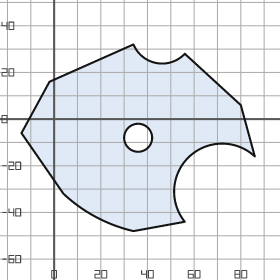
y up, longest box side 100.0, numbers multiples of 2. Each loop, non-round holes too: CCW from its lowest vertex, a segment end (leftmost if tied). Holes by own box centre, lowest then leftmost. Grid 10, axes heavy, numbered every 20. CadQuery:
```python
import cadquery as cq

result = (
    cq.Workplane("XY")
    .moveTo(34.0, -48.0)
    .lineTo(56.0, -44.0)
    .threePointArc((58.0, -16.0), (86.0, -16.0))
    .lineTo(80.0, 6.0)
    .lineTo(56.0, 28.0)
    .threePointArc((44.0, 24.0), (34.0, 32.0))
    .lineTo(-2.0, 16.0)
    .lineTo(-14.0, -6.0)
    .lineTo(4.0, -32.0)
    .threePointArc((18.0, -42.0), (34.0, -48.0))
    .close()
    .moveTo(36.0, -8.0)
    .circle(6.0)
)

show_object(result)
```